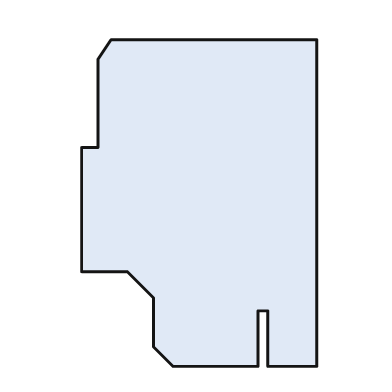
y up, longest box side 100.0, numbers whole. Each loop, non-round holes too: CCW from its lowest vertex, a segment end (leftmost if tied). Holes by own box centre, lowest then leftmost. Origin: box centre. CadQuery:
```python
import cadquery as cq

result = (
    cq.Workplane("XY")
    .moveTo(-8.0, -50.0)
    .lineTo(18.0, -50.0)
    .lineTo(18.0, -33.0)
    .lineTo(21.0, -33.0)
    .lineTo(21.0, -50.0)
    .lineTo(36.0, -50.0)
    .lineTo(36.0, 50.0)
    .lineTo(-27.0, 50.0)
    .lineTo(-31.0, 44.0)
    .lineTo(-31.0, 17.0)
    .lineTo(-36.0, 17.0)
    .lineTo(-36.0, -21.0)
    .lineTo(-22.0, -21.0)
    .lineTo(-14.0, -29.0)
    .lineTo(-14.0, -44.0)
    .close()
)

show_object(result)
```